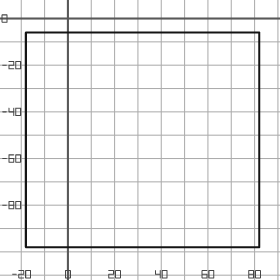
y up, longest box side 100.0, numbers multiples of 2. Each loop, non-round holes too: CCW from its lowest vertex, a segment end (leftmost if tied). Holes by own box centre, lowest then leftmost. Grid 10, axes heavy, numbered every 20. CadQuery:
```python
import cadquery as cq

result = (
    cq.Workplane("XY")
    .moveTo(-18.0, -98.0)
    .lineTo(82.0, -98.0)
    .lineTo(82.0, -6.0)
    .lineTo(-18.0, -6.0)
    .close()
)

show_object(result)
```